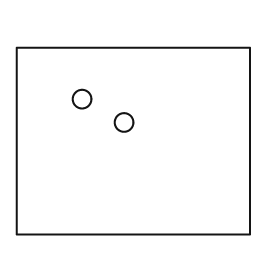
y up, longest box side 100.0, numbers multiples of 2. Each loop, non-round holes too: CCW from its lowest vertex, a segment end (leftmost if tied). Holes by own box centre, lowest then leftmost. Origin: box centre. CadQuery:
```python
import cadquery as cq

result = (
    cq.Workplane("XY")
    .moveTo(-50.0, -40.0)
    .lineTo(50.0, -40.0)
    .lineTo(50.0, 40.0)
    .lineTo(-50.0, 40.0)
    .close()
    .moveTo(-4.0, 8.0)
    .circle(4.0)
    .moveTo(-22.0, 18.0)
    .circle(4.0)
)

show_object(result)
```